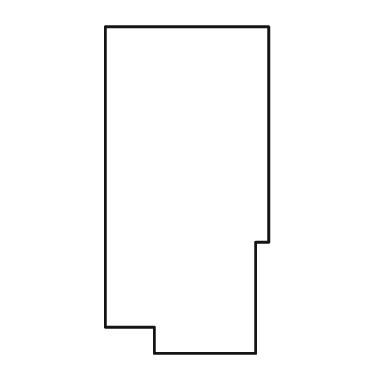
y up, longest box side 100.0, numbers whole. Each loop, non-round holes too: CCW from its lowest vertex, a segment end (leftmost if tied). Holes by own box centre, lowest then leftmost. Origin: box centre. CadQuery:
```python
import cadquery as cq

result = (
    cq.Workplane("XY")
    .moveTo(-10.0, -50.0)
    .lineTo(21.0, -50.0)
    .lineTo(21.0, -16.0)
    .lineTo(25.0, -16.0)
    .lineTo(25.0, 50.0)
    .lineTo(-25.0, 50.0)
    .lineTo(-25.0, -42.0)
    .lineTo(-10.0, -42.0)
    .close()
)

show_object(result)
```